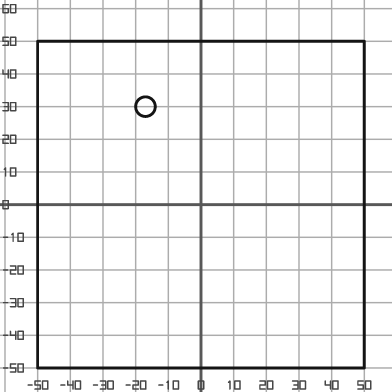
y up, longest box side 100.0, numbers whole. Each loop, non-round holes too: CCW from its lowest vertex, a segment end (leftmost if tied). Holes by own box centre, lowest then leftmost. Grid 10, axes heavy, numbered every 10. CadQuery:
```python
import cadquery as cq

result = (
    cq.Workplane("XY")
    .moveTo(-50.0, -50.0)
    .lineTo(50.0, -50.0)
    .lineTo(50.0, 50.0)
    .lineTo(-50.0, 50.0)
    .close()
    .moveTo(-17.0, 30.0)
    .circle(3.0)
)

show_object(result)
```